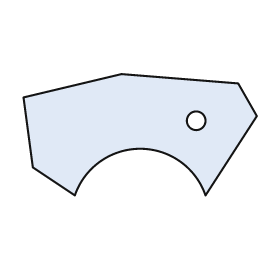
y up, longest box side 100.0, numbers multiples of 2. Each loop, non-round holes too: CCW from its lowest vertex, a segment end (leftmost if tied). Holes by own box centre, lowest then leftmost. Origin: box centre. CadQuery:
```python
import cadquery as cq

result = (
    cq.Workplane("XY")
    .moveTo(-28.0, -26.0)
    .threePointArc((0.0, -6.0), (28.0, -26.0))
    .lineTo(50.0, 8.0)
    .lineTo(42.0, 22.0)
    .lineTo(-8.0, 26.0)
    .lineTo(-50.0, 16.0)
    .lineTo(-46.0, -14.0)
    .close()
    .moveTo(24.0, 6.0)
    .circle(4.0)
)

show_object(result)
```